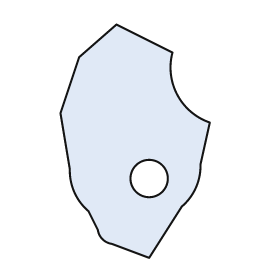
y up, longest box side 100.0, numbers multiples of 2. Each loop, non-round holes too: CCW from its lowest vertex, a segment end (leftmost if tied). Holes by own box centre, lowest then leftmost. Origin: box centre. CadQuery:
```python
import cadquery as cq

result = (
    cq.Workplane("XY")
    .moveTo(6.0, -50.0)
    .lineTo(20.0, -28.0)
    .threePointArc((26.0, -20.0), (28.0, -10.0))
    .lineTo(32.0, 8.0)
    .threePointArc((18.0, 20.0), (16.0, 38.0))
    .lineTo(-8.0, 50.0)
    .lineTo(-24.0, 36.0)
    .lineTo(-32.0, 12.0)
    .lineTo(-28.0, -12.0)
    .threePointArc((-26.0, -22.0), (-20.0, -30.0))
    .lineTo(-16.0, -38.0)
    .threePointArc((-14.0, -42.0), (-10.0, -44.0))
    .close()
    .moveTo(6.0, -16.0)
    .circle(8.0)
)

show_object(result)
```